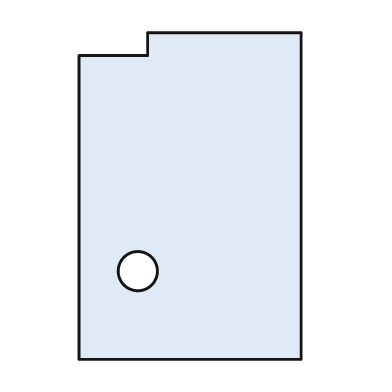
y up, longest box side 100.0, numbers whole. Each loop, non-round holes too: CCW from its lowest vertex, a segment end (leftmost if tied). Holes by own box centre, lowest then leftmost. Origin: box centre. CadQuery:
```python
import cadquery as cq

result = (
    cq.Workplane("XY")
    .moveTo(-34.0, -50.0)
    .lineTo(34.0, -50.0)
    .lineTo(34.0, 50.0)
    .lineTo(-13.0, 50.0)
    .lineTo(-13.0, 43.0)
    .lineTo(-34.0, 43.0)
    .close()
    .moveTo(-16.0, -23.0)
    .circle(6.0)
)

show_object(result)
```